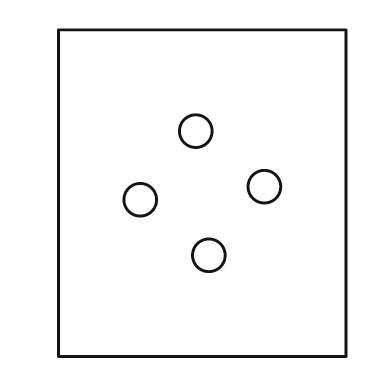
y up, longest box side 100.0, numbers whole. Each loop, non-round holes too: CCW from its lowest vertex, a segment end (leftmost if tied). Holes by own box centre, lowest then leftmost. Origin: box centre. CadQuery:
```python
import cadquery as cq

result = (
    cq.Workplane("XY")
    .moveTo(-44.0, -50.0)
    .lineTo(44.0, -50.0)
    .lineTo(44.0, 50.0)
    .lineTo(-44.0, 50.0)
    .close()
    .moveTo(2.0, -19.0)
    .circle(5.0)
    .moveTo(-19.0, -2.0)
    .circle(5.0)
    .moveTo(19.0, 2.0)
    .circle(5.0)
    .moveTo(-2.0, 19.0)
    .circle(5.0)
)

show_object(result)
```